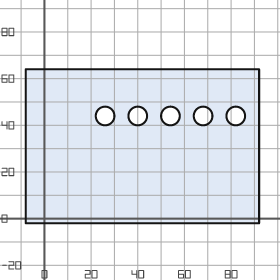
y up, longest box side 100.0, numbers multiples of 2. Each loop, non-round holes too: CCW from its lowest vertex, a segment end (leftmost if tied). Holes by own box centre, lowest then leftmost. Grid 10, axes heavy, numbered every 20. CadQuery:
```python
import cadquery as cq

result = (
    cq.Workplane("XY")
    .moveTo(-8.0, -2.0)
    .lineTo(92.0, -2.0)
    .lineTo(92.0, 64.0)
    .lineTo(-8.0, 64.0)
    .close()
    .moveTo(26.0, 44.0)
    .circle(4.0)
    .moveTo(40.0, 44.0)
    .circle(4.0)
    .moveTo(54.0, 44.0)
    .circle(4.0)
    .moveTo(68.0, 44.0)
    .circle(4.0)
    .moveTo(82.0, 44.0)
    .circle(4.0)
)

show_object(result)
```